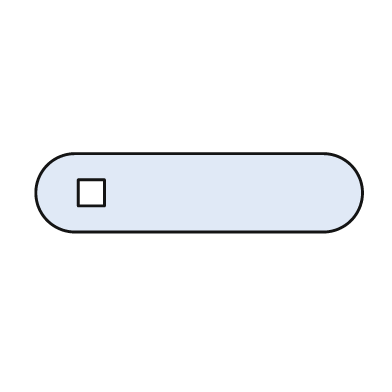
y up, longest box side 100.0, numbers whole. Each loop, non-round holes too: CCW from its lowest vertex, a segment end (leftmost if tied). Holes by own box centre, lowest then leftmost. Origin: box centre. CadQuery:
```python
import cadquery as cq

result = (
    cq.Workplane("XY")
    .moveTo(-38.0, -12.0)
    .lineTo(38.0, -12.0)
    .threePointArc((50.0, 0.0), (38.0, 12.0))
    .lineTo(-38.0, 12.0)
    .threePointArc((-50.0, 0.0), (-38.0, -12.0))
    .close()
    .moveTo(-37.0, -4.0)
    .lineTo(-29.0, -4.0)
    .lineTo(-29.0, 4.0)
    .lineTo(-37.0, 4.0)
    .close()
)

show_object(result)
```